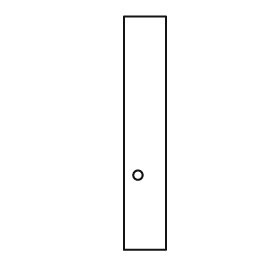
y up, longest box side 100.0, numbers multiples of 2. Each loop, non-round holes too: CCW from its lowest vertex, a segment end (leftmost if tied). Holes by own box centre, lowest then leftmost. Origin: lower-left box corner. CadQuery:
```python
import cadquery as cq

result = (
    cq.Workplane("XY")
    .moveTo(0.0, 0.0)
    .lineTo(18.0, 0.0)
    .lineTo(18.0, 100.0)
    .lineTo(0.0, 100.0)
    .close()
    .moveTo(6.0, 32.0)
    .circle(2.0)
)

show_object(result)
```